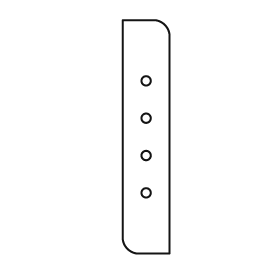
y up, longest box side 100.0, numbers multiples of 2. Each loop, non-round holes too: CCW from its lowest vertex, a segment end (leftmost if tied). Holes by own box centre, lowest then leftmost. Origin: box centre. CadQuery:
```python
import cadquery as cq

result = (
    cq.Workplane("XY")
    .moveTo(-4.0, -50.0)
    .lineTo(10.0, -50.0)
    .lineTo(10.0, 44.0)
    .threePointArc((8.0, 48.0), (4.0, 50.0))
    .lineTo(-10.0, 50.0)
    .lineTo(-10.0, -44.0)
    .threePointArc((-8.0, -48.0), (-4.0, -50.0))
    .close()
    .moveTo(0.0, -24.0)
    .circle(2.0)
    .moveTo(0.0, -8.0)
    .circle(2.0)
    .moveTo(0.0, 8.0)
    .circle(2.0)
    .moveTo(0.0, 24.0)
    .circle(2.0)
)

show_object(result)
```